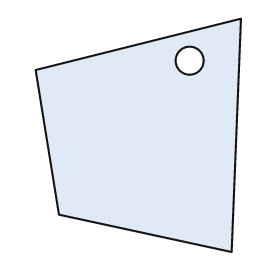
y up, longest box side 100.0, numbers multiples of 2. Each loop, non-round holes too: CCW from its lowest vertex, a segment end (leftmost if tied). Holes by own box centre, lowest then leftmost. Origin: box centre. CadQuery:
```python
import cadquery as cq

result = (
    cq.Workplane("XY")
    .moveTo(40.0, -50.0)
    .lineTo(44.0, 50.0)
    .lineTo(-44.0, 28.0)
    .lineTo(-34.0, -34.0)
    .close()
    .moveTo(22.0, 32.0)
    .circle(6.0)
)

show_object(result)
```